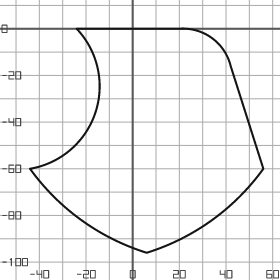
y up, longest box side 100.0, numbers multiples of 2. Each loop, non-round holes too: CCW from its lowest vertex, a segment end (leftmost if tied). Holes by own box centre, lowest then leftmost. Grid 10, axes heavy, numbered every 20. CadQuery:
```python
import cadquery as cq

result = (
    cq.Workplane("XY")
    .moveTo(6.0, -96.0)
    .threePointArc((34.0, -82.0), (56.0, -60.0))
    .lineTo(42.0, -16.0)
    .threePointArc((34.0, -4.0), (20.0, 0.0))
    .lineTo(-24.0, 0.0)
    .threePointArc((-16.0, -36.0), (-44.0, -60.0))
    .threePointArc((-22.0, -82.0), (6.0, -96.0))
    .close()
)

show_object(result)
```